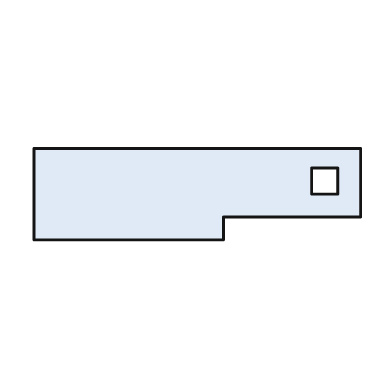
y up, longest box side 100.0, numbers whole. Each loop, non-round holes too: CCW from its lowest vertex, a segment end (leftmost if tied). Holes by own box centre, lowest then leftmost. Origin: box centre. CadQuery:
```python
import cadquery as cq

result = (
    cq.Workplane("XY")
    .moveTo(-50.0, -14.0)
    .lineTo(8.0, -14.0)
    .lineTo(8.0, -7.0)
    .lineTo(50.0, -7.0)
    .lineTo(50.0, 14.0)
    .lineTo(-50.0, 14.0)
    .close()
    .moveTo(35.0, 0.0)
    .lineTo(43.0, 0.0)
    .lineTo(43.0, 8.0)
    .lineTo(35.0, 8.0)
    .close()
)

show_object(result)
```